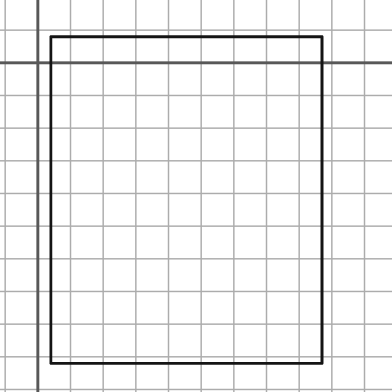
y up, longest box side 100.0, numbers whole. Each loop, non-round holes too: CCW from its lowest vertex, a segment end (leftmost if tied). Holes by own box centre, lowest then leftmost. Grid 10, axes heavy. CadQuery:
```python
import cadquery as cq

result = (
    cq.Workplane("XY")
    .moveTo(4.0, -92.0)
    .lineTo(87.0, -92.0)
    .lineTo(87.0, 8.0)
    .lineTo(4.0, 8.0)
    .close()
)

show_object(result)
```